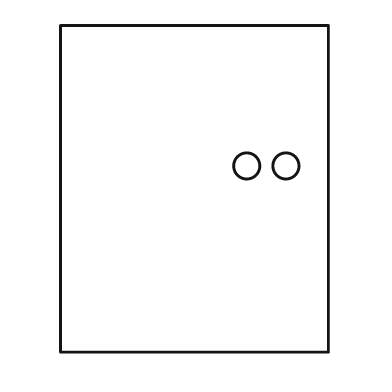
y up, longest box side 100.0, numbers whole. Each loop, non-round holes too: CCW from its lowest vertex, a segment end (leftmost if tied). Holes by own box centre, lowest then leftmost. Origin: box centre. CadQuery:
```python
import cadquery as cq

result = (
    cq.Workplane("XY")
    .moveTo(-41.0, -50.0)
    .lineTo(41.0, -50.0)
    .lineTo(41.0, 50.0)
    .lineTo(-41.0, 50.0)
    .close()
    .moveTo(16.0, 7.0)
    .circle(4.0)
    .moveTo(28.0, 7.0)
    .circle(4.0)
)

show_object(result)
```